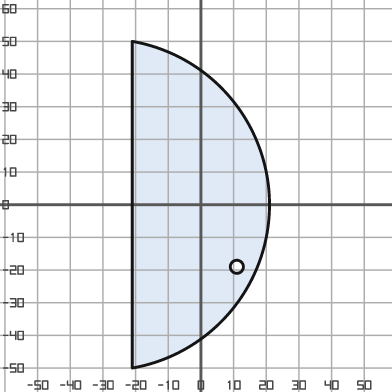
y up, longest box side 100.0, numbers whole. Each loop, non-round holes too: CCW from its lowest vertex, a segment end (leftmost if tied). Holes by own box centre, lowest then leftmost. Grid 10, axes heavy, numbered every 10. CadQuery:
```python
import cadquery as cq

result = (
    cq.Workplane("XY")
    .moveTo(-21.0, -50.0)
    .threePointArc((21.0, 0.0), (-21.0, 50.0))
    .close()
    .moveTo(11.0, -19.0)
    .circle(2.0)
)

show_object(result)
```